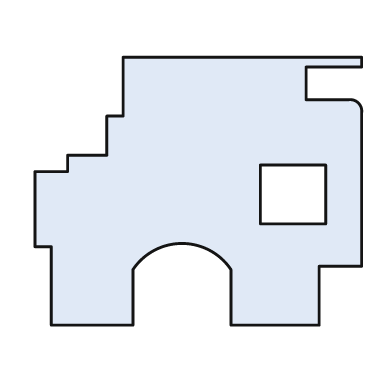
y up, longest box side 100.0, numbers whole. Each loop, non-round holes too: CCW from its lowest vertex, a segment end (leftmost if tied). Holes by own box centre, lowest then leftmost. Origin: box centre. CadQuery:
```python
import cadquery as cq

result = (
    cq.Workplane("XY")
    .moveTo(-45.0, -41.0)
    .lineTo(-20.0, -41.0)
    .lineTo(-20.0, -24.0)
    .threePointArc((-5.0, -16.0), (10.0, -24.0))
    .lineTo(10.0, -41.0)
    .lineTo(37.0, -41.0)
    .lineTo(37.0, -23.0)
    .lineTo(50.0, -23.0)
    .lineTo(50.0, 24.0)
    .threePointArc((49.0, 27.0), (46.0, 28.0))
    .lineTo(33.0, 28.0)
    .lineTo(33.0, 38.0)
    .lineTo(50.0, 38.0)
    .lineTo(50.0, 41.0)
    .lineTo(-23.0, 41.0)
    .lineTo(-23.0, 23.0)
    .lineTo(-28.0, 23.0)
    .lineTo(-28.0, 11.0)
    .lineTo(-40.0, 11.0)
    .lineTo(-40.0, 6.0)
    .lineTo(-50.0, 6.0)
    .lineTo(-50.0, -17.0)
    .lineTo(-45.0, -17.0)
    .close()
    .moveTo(19.0, -10.0)
    .lineTo(39.0, -10.0)
    .lineTo(39.0, 8.0)
    .lineTo(19.0, 8.0)
    .close()
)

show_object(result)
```